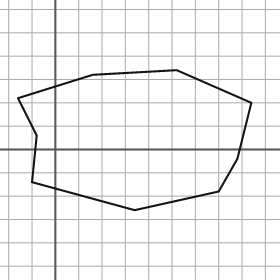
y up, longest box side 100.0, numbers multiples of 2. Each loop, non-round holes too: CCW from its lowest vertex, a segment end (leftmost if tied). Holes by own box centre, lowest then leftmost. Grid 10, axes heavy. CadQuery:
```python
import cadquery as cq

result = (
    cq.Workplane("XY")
    .moveTo(34.0, -26.0)
    .lineTo(70.0, -18.0)
    .lineTo(78.0, -4.0)
    .lineTo(84.0, 20.0)
    .lineTo(52.0, 34.0)
    .lineTo(16.0, 32.0)
    .lineTo(-16.0, 22.0)
    .lineTo(-8.0, 6.0)
    .lineTo(-10.0, -14.0)
    .close()
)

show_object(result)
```